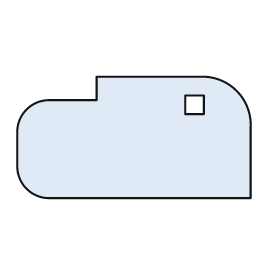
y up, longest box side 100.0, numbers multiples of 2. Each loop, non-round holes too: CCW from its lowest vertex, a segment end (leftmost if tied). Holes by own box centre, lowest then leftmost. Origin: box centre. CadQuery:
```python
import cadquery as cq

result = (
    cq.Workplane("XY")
    .moveTo(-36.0, -26.0)
    .lineTo(50.0, -26.0)
    .lineTo(50.0, 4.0)
    .threePointArc((44.0, 20.0), (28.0, 26.0))
    .lineTo(-16.0, 26.0)
    .lineTo(-16.0, 16.0)
    .lineTo(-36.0, 16.0)
    .threePointArc((-46.0, 12.0), (-50.0, 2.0))
    .lineTo(-50.0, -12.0)
    .threePointArc((-46.0, -22.0), (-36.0, -26.0))
    .close()
    .moveTo(22.0, 10.0)
    .lineTo(30.0, 10.0)
    .lineTo(30.0, 18.0)
    .lineTo(22.0, 18.0)
    .close()
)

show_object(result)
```